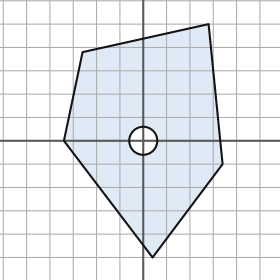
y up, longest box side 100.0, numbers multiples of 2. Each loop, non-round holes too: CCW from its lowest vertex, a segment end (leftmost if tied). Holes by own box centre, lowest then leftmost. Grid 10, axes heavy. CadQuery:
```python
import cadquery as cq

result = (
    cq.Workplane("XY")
    .moveTo(4.0, -50.0)
    .lineTo(34.0, -10.0)
    .lineTo(28.0, 50.0)
    .lineTo(-26.0, 38.0)
    .lineTo(-34.0, 0.0)
    .close()
    .moveTo(0.0, 0.0)
    .circle(6.0)
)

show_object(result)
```